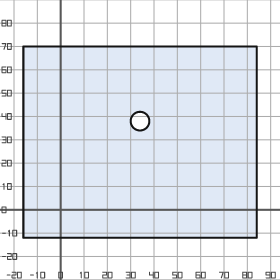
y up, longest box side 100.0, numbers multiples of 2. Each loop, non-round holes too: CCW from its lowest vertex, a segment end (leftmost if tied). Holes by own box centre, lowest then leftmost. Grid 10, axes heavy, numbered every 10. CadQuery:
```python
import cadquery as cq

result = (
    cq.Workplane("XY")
    .moveTo(-16.0, -12.0)
    .lineTo(84.0, -12.0)
    .lineTo(84.0, 70.0)
    .lineTo(-16.0, 70.0)
    .close()
    .moveTo(34.0, 38.0)
    .circle(4.0)
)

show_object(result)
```